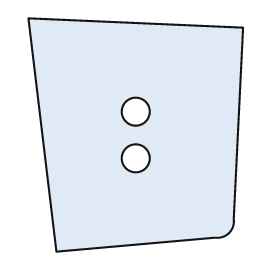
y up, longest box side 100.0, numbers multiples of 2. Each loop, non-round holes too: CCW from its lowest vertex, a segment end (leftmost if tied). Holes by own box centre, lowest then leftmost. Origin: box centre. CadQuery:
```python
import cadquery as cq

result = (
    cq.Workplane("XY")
    .moveTo(-34.0, -50.0)
    .lineTo(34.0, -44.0)
    .threePointArc((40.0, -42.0), (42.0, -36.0))
    .lineTo(46.0, 46.0)
    .lineTo(-46.0, 50.0)
    .close()
    .moveTo(0.0, -10.0)
    .circle(6.0)
    .moveTo(0.0, 10.0)
    .circle(6.0)
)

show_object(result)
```